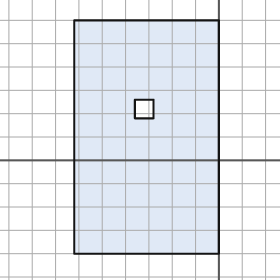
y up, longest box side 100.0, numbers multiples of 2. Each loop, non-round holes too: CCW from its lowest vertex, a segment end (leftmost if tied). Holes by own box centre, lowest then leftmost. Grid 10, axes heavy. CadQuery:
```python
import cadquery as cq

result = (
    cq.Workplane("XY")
    .moveTo(-62.0, -40.0)
    .lineTo(0.0, -40.0)
    .lineTo(0.0, 60.0)
    .lineTo(-62.0, 60.0)
    .close()
    .moveTo(-36.0, 18.0)
    .lineTo(-28.0, 18.0)
    .lineTo(-28.0, 26.0)
    .lineTo(-36.0, 26.0)
    .close()
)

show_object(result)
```